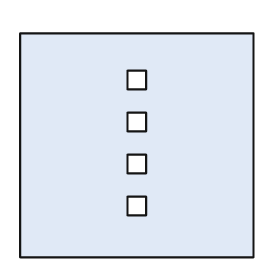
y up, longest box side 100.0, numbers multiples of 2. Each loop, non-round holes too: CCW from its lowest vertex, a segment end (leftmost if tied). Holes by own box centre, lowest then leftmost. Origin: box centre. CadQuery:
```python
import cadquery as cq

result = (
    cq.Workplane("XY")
    .moveTo(-50.0, -48.0)
    .lineTo(50.0, -48.0)
    .lineTo(50.0, 48.0)
    .lineTo(-50.0, 48.0)
    .close()
    .moveTo(-4.0, -30.0)
    .lineTo(4.0, -30.0)
    .lineTo(4.0, -22.0)
    .lineTo(-4.0, -22.0)
    .close()
    .moveTo(-4.0, -12.0)
    .lineTo(4.0, -12.0)
    .lineTo(4.0, -4.0)
    .lineTo(-4.0, -4.0)
    .close()
    .moveTo(-4.0, 6.0)
    .lineTo(4.0, 6.0)
    .lineTo(4.0, 14.0)
    .lineTo(-4.0, 14.0)
    .close()
    .moveTo(-4.0, 24.0)
    .lineTo(4.0, 24.0)
    .lineTo(4.0, 32.0)
    .lineTo(-4.0, 32.0)
    .close()
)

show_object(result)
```